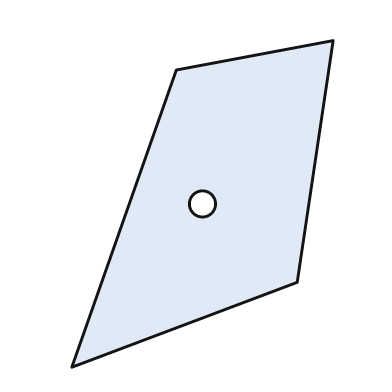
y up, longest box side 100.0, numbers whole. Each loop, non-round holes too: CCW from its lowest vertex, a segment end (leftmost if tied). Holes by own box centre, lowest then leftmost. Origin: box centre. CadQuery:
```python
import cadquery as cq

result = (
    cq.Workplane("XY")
    .moveTo(-40.0, -50.0)
    .lineTo(29.0, -24.0)
    .lineTo(40.0, 50.0)
    .lineTo(-8.0, 41.0)
    .close()
    .moveTo(0.0, 0.0)
    .circle(4.0)
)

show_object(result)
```